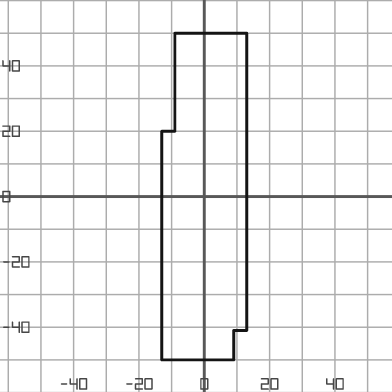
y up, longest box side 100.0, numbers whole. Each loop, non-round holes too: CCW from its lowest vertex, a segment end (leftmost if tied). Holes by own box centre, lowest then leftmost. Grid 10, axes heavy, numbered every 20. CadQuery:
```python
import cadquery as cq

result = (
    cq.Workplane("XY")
    .moveTo(-13.0, -50.0)
    .lineTo(9.0, -50.0)
    .lineTo(9.0, -41.0)
    .lineTo(13.0, -41.0)
    .lineTo(13.0, 50.0)
    .lineTo(-9.0, 50.0)
    .lineTo(-9.0, 20.0)
    .lineTo(-13.0, 20.0)
    .close()
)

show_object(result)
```